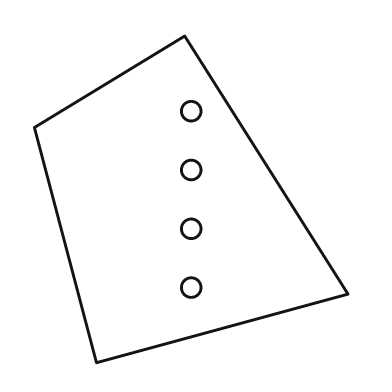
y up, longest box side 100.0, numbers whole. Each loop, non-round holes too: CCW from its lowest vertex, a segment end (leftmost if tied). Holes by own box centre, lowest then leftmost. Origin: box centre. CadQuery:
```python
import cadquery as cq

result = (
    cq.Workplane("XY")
    .moveTo(-29.0, -50.0)
    .lineTo(48.0, -29.0)
    .lineTo(-2.0, 50.0)
    .lineTo(-48.0, 22.0)
    .close()
    .moveTo(0.0, -27.0)
    .circle(3.0)
    .moveTo(0.0, -9.0)
    .circle(3.0)
    .moveTo(0.0, 9.0)
    .circle(3.0)
    .moveTo(0.0, 27.0)
    .circle(3.0)
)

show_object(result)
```